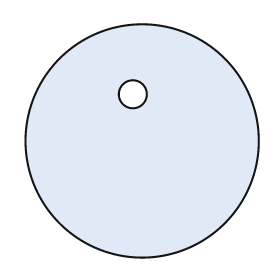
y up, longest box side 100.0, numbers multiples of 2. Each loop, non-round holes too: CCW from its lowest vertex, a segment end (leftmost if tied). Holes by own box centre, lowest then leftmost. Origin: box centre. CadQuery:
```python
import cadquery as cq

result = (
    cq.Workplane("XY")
    .moveTo(0.0, 0.0)
    .circle(50.0)
    .moveTo(-4.0, 20.0)
    .circle(6.0)
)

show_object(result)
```